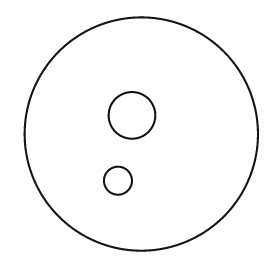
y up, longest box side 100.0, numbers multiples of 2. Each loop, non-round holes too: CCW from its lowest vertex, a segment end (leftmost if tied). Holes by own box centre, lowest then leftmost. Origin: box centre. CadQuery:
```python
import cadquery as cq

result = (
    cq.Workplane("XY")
    .moveTo(0.0, 0.0)
    .circle(50.0)
    .moveTo(-10.0, -20.0)
    .circle(6.0)
    .moveTo(-4.0, 8.0)
    .circle(10.0)
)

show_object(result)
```